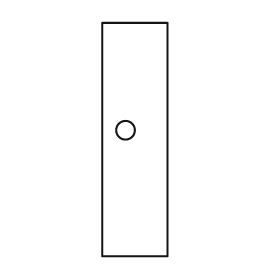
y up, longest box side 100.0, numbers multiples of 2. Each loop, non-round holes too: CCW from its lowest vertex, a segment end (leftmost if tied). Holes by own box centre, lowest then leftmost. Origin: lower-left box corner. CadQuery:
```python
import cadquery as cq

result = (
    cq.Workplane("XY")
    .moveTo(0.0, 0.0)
    .lineTo(28.0, 0.0)
    .lineTo(28.0, 100.0)
    .lineTo(0.0, 100.0)
    .close()
    .moveTo(10.0, 54.0)
    .circle(4.0)
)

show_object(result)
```